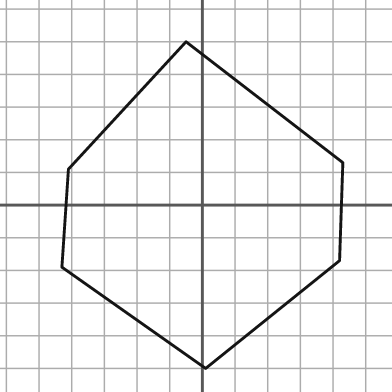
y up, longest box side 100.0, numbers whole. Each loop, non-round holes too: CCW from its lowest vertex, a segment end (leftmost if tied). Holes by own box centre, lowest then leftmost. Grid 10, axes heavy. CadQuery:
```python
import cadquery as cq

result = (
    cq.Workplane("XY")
    .moveTo(1.0, -50.0)
    .lineTo(42.0, -17.0)
    .lineTo(43.0, 13.0)
    .lineTo(-5.0, 50.0)
    .lineTo(-41.0, 11.0)
    .lineTo(-43.0, -19.0)
    .close()
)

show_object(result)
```